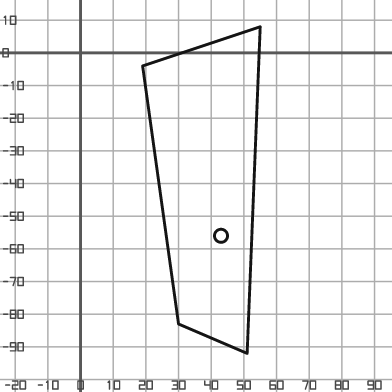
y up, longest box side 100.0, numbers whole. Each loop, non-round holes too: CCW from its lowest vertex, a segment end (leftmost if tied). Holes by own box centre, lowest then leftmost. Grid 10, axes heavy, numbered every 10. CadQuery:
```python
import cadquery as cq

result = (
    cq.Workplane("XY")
    .moveTo(51.0, -92.0)
    .lineTo(55.0, 8.0)
    .lineTo(19.0, -4.0)
    .lineTo(30.0, -83.0)
    .close()
    .moveTo(43.0, -56.0)
    .circle(2.0)
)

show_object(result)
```